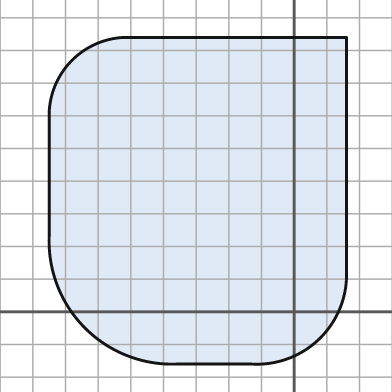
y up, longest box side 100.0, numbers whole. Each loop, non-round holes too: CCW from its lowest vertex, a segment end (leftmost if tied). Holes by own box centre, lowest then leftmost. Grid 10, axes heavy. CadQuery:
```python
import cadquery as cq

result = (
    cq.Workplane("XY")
    .moveTo(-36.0, -16.0)
    .lineTo(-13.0, -16.0)
    .threePointArc((8.0, -8.0), (16.0, 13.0))
    .lineTo(16.0, 84.0)
    .lineTo(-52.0, 84.0)
    .threePointArc((-68.0, 77.0), (-75.0, 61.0))
    .lineTo(-75.0, 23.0)
    .threePointArc((-64.0, -5.0), (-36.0, -16.0))
    .close()
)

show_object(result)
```